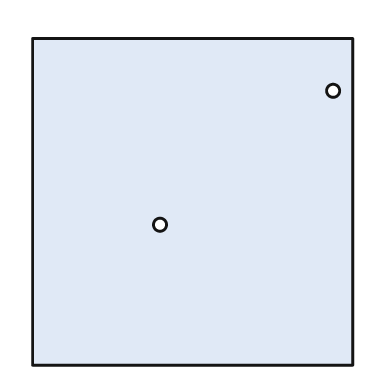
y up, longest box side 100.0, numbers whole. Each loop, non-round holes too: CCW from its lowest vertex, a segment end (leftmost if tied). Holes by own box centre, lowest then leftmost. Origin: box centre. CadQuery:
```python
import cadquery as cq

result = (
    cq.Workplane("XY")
    .moveTo(-49.0, -50.0)
    .lineTo(49.0, -50.0)
    .lineTo(49.0, 50.0)
    .lineTo(-49.0, 50.0)
    .close()
    .moveTo(-10.0, -7.0)
    .circle(2.0)
    .moveTo(43.0, 34.0)
    .circle(2.0)
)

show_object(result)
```